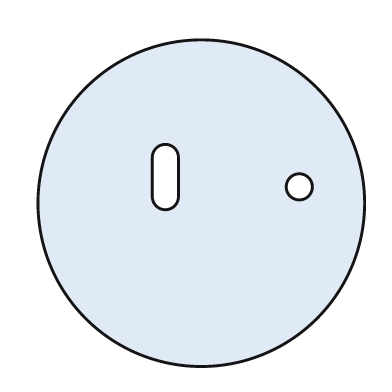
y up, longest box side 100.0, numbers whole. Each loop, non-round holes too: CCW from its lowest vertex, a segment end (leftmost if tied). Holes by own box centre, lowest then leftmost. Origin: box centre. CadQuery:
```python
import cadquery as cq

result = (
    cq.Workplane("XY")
    .moveTo(0.0, 0.0)
    .circle(50.0)
    .moveTo(30.0, 5.0)
    .circle(4.0)
    .moveTo(-15.0, 2.0)
    .threePointArc((-11.0, -2.0), (-7.0, 2.0))
    .lineTo(-7.0, 14.0)
    .threePointArc((-11.0, 18.0), (-15.0, 14.0))
    .close()
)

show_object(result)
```